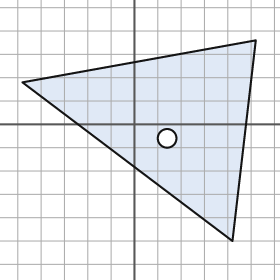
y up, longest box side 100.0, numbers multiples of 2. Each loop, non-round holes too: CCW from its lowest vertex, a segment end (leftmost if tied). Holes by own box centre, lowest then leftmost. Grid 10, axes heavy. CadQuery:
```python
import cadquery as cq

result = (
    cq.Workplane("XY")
    .moveTo(42.0, -50.0)
    .lineTo(52.0, 36.0)
    .lineTo(-48.0, 18.0)
    .close()
    .moveTo(14.0, -6.0)
    .circle(4.0)
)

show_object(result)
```